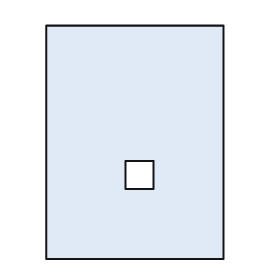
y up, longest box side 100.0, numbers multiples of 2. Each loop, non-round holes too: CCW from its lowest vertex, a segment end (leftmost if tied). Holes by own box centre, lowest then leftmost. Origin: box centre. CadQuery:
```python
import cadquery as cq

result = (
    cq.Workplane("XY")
    .moveTo(-38.0, -50.0)
    .lineTo(38.0, -50.0)
    .lineTo(38.0, 50.0)
    .lineTo(-38.0, 50.0)
    .close()
    .moveTo(-4.0, -20.0)
    .lineTo(8.0, -20.0)
    .lineTo(8.0, -8.0)
    .lineTo(-4.0, -8.0)
    .close()
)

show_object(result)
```